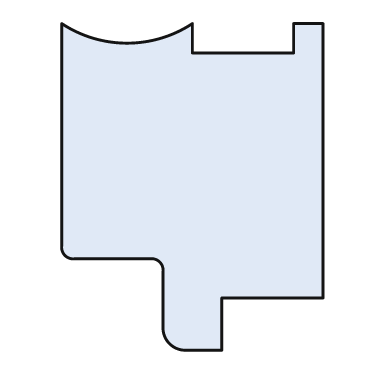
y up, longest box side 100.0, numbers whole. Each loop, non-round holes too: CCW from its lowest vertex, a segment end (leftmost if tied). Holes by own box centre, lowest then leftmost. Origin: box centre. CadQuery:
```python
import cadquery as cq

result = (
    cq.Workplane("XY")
    .moveTo(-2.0, -50.0)
    .lineTo(9.0, -50.0)
    .lineTo(9.0, -34.0)
    .lineTo(40.0, -34.0)
    .lineTo(40.0, 50.0)
    .lineTo(31.0, 50.0)
    .lineTo(31.0, 41.0)
    .lineTo(0.0, 41.0)
    .lineTo(0.0, 50.0)
    .threePointArc((-20.0, 44.0), (-40.0, 50.0))
    .lineTo(-40.0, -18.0)
    .threePointArc((-39.0, -21.0), (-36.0, -22.0))
    .lineTo(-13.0, -22.0)
    .threePointArc((-10.0, -23.0), (-9.0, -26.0))
    .lineTo(-9.0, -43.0)
    .threePointArc((-7.0, -48.0), (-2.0, -50.0))
    .close()
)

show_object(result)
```